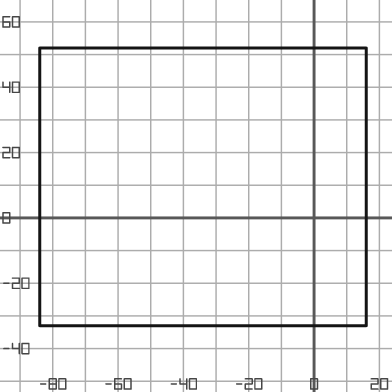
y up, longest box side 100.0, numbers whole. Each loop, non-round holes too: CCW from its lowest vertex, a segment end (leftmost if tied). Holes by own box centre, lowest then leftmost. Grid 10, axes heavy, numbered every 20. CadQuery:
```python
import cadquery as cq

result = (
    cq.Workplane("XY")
    .moveTo(-84.0, -33.0)
    .lineTo(16.0, -33.0)
    .lineTo(16.0, 52.0)
    .lineTo(-84.0, 52.0)
    .close()
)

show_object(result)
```